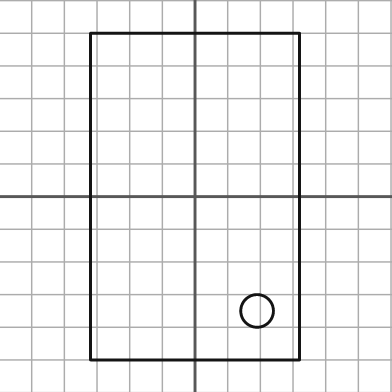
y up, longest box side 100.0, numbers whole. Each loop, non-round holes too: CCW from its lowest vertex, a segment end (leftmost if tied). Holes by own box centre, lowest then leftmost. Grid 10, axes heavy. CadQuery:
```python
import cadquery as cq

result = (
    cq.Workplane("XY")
    .moveTo(-32.0, -50.0)
    .lineTo(32.0, -50.0)
    .lineTo(32.0, 50.0)
    .lineTo(-32.0, 50.0)
    .close()
    .moveTo(19.0, -35.0)
    .circle(5.0)
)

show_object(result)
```